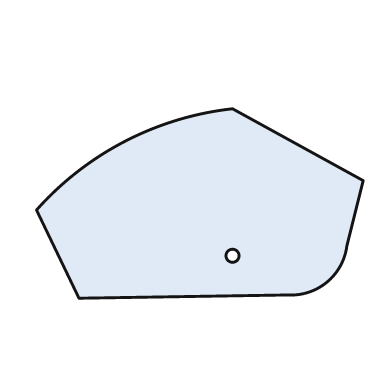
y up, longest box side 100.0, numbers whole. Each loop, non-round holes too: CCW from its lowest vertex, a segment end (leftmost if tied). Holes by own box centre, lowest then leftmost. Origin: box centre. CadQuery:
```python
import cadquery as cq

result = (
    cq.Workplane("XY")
    .moveTo(-37.0, -29.0)
    .lineTo(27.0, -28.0)
    .threePointArc((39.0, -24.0), (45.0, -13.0))
    .lineTo(50.0, 7.0)
    .lineTo(10.0, 29.0)
    .threePointArc((-23.0, 19.0), (-50.0, -2.0))
    .close()
    .moveTo(10.0, -16.0)
    .circle(2.0)
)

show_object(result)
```